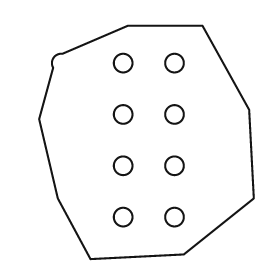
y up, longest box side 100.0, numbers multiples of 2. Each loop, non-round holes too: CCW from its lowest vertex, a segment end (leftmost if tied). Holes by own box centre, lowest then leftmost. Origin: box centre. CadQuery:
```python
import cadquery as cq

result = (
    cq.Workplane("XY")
    .moveTo(-24.0, -50.0)
    .lineTo(16.0, -48.0)
    .lineTo(46.0, -24.0)
    .lineTo(44.0, 14.0)
    .lineTo(24.0, 50.0)
    .lineTo(-8.0, 50.0)
    .lineTo(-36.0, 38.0)
    .threePointArc((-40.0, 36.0), (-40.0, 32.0))
    .lineTo(-46.0, 10.0)
    .lineTo(-38.0, -24.0)
    .close()
    .moveTo(-10.0, -32.0)
    .circle(4.0)
    .moveTo(12.0, -32.0)
    .circle(4.0)
    .moveTo(-10.0, -10.0)
    .circle(4.0)
    .moveTo(12.0, -10.0)
    .circle(4.0)
    .moveTo(-10.0, 12.0)
    .circle(4.0)
    .moveTo(12.0, 12.0)
    .circle(4.0)
    .moveTo(-10.0, 34.0)
    .circle(4.0)
    .moveTo(12.0, 34.0)
    .circle(4.0)
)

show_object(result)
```